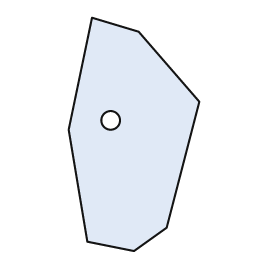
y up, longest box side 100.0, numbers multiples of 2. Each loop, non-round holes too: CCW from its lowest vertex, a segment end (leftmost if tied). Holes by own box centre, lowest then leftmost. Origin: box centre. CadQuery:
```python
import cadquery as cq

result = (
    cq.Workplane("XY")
    .moveTo(0.0, -50.0)
    .lineTo(14.0, -40.0)
    .lineTo(28.0, 14.0)
    .lineTo(2.0, 44.0)
    .lineTo(-18.0, 50.0)
    .lineTo(-28.0, 2.0)
    .lineTo(-20.0, -46.0)
    .close()
    .moveTo(-10.0, 6.0)
    .circle(4.0)
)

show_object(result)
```